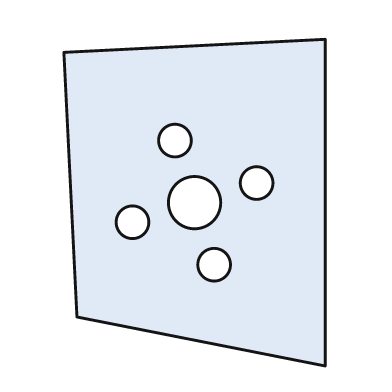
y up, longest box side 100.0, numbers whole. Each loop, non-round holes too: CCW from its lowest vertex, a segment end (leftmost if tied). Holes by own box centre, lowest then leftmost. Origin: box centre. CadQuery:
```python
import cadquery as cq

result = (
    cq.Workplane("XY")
    .moveTo(40.0, -50.0)
    .lineTo(40.0, 50.0)
    .lineTo(-40.0, 46.0)
    .lineTo(-36.0, -35.0)
    .close()
    .moveTo(6.0, -19.0)
    .circle(5.0)
    .moveTo(-19.0, -6.0)
    .circle(5.0)
    .moveTo(0.0, 0.0)
    .circle(8.0)
    .moveTo(19.0, 6.0)
    .circle(5.0)
    .moveTo(-6.0, 19.0)
    .circle(5.0)
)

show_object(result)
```